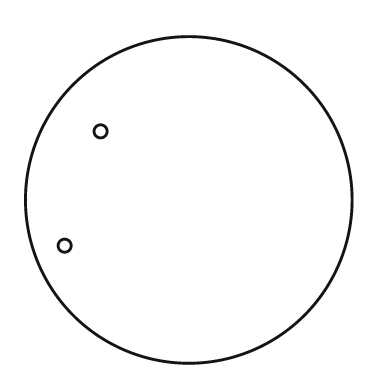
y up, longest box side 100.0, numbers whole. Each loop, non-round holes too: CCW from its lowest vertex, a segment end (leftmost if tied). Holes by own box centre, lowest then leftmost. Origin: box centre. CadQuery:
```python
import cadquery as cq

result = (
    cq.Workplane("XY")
    .moveTo(0.0, 0.0)
    .circle(50.0)
    .moveTo(-38.0, -14.0)
    .circle(2.0)
    .moveTo(-27.0, 21.0)
    .circle(2.0)
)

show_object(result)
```